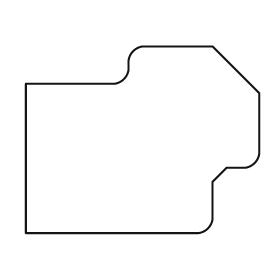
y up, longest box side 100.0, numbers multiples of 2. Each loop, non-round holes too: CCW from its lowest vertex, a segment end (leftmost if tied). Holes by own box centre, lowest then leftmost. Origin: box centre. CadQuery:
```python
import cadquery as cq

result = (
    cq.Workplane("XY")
    .moveTo(-50.0, -40.0)
    .lineTo(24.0, -40.0)
    .threePointArc((28.0, -38.0), (30.0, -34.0))
    .lineTo(30.0, -18.0)
    .lineTo(36.0, -12.0)
    .lineTo(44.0, -12.0)
    .threePointArc((48.0, -10.0), (50.0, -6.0))
    .lineTo(50.0, 20.0)
    .lineTo(30.0, 40.0)
    .lineTo(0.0, 40.0)
    .threePointArc((-4.0, 38.0), (-6.0, 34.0))
    .lineTo(-6.0, 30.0)
    .threePointArc((-8.0, 26.0), (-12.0, 24.0))
    .lineTo(-50.0, 24.0)
    .close()
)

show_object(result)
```